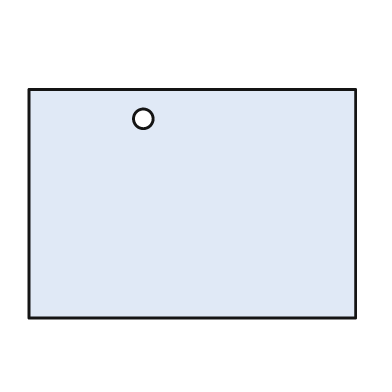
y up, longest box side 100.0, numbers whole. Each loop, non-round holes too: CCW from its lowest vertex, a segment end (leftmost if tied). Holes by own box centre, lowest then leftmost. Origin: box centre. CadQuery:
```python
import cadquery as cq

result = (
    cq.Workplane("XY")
    .moveTo(-50.0, -35.0)
    .lineTo(50.0, -35.0)
    .lineTo(50.0, 35.0)
    .lineTo(-50.0, 35.0)
    .close()
    .moveTo(-15.0, 26.0)
    .circle(3.0)
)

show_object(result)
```